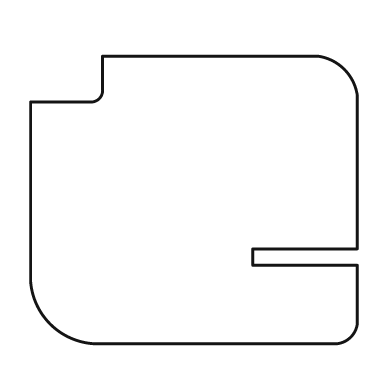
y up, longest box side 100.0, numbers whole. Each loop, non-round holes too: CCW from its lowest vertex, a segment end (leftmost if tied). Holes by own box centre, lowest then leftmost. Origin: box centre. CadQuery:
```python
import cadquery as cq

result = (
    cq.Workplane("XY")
    .moveTo(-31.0, -44.0)
    .lineTo(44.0, -44.0)
    .threePointArc((48.0, -42.0), (50.0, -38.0))
    .lineTo(50.0, -20.0)
    .lineTo(18.0, -20.0)
    .lineTo(18.0, -15.0)
    .lineTo(50.0, -15.0)
    .lineTo(50.0, 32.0)
    .threePointArc((46.0, 40.0), (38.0, 44.0))
    .lineTo(-28.0, 44.0)
    .lineTo(-28.0, 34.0)
    .threePointArc((-29.0, 31.0), (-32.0, 30.0))
    .lineTo(-50.0, 30.0)
    .lineTo(-50.0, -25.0)
    .threePointArc((-44.0, -38.0), (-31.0, -44.0))
    .close()
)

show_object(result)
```